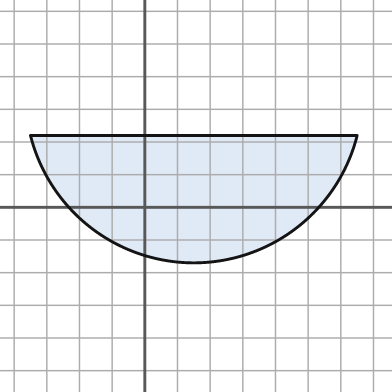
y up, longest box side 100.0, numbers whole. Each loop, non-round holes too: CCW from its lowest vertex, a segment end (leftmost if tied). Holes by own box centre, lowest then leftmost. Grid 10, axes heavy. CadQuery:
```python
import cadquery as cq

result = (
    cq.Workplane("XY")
    .moveTo(-35.0, 22.0)
    .threePointArc((15.0, -17.0), (65.0, 22.0))
    .close()
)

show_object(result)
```